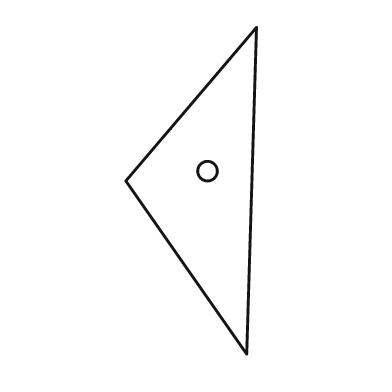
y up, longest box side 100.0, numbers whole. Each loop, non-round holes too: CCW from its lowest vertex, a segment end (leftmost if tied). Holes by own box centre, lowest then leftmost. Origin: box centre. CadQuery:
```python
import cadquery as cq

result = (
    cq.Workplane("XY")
    .moveTo(17.0, -50.0)
    .lineTo(20.0, 50.0)
    .lineTo(-20.0, 3.0)
    .close()
    .moveTo(5.0, 6.0)
    .circle(3.0)
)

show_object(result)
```